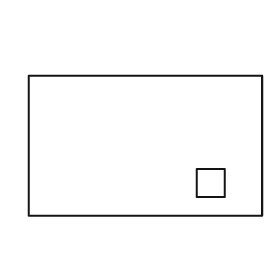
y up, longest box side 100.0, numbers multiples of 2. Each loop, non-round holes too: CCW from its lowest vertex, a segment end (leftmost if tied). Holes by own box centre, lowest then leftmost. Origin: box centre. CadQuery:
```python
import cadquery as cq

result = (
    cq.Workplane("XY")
    .moveTo(-50.0, -30.0)
    .lineTo(50.0, -30.0)
    .lineTo(50.0, 30.0)
    .lineTo(-50.0, 30.0)
    .close()
    .moveTo(22.0, -22.0)
    .lineTo(34.0, -22.0)
    .lineTo(34.0, -10.0)
    .lineTo(22.0, -10.0)
    .close()
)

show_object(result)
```